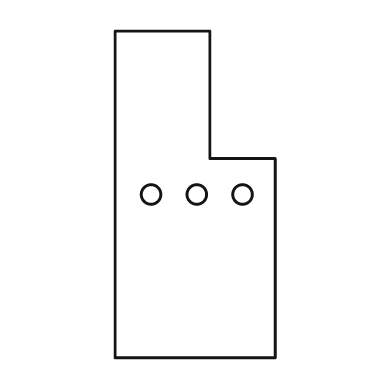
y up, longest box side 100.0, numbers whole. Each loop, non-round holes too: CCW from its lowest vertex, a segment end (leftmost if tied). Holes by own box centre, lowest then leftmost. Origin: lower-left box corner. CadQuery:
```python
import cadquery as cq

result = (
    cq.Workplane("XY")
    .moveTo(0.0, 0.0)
    .lineTo(49.0, 0.0)
    .lineTo(49.0, 61.0)
    .lineTo(29.0, 61.0)
    .lineTo(29.0, 100.0)
    .lineTo(0.0, 100.0)
    .close()
    .moveTo(11.0, 50.0)
    .circle(3.0)
    .moveTo(25.0, 50.0)
    .circle(3.0)
    .moveTo(39.0, 50.0)
    .circle(3.0)
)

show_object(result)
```